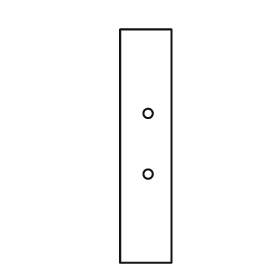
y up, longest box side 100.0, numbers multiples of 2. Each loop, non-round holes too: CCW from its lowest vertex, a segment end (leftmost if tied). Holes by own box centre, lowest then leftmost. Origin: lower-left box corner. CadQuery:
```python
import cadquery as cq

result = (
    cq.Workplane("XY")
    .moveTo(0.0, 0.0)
    .lineTo(22.0, 0.0)
    .lineTo(22.0, 100.0)
    .lineTo(0.0, 100.0)
    .close()
    .moveTo(12.0, 38.0)
    .circle(2.0)
    .moveTo(12.0, 64.0)
    .circle(2.0)
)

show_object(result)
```